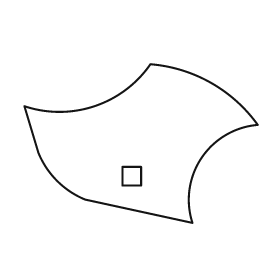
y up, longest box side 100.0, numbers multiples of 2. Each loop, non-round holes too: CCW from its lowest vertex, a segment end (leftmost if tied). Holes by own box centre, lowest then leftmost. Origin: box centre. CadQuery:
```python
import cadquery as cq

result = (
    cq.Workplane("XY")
    .moveTo(22.0, -34.0)
    .threePointArc((26.0, -6.0), (50.0, 8.0))
    .threePointArc((30.0, 26.0), (4.0, 34.0))
    .threePointArc((-20.0, 16.0), (-50.0, 16.0))
    .lineTo(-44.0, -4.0)
    .threePointArc((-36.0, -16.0), (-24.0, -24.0))
    .close()
    .moveTo(-8.0, -18.0)
    .lineTo(0.0, -18.0)
    .lineTo(0.0, -10.0)
    .lineTo(-8.0, -10.0)
    .close()
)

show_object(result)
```